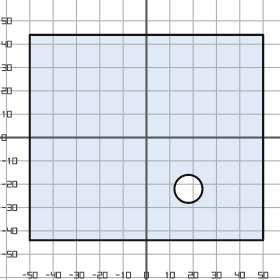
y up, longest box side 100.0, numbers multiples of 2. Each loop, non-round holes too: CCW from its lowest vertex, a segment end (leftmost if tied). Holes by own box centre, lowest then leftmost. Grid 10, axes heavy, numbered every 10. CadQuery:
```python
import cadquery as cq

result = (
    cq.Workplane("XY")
    .moveTo(-50.0, -44.0)
    .lineTo(50.0, -44.0)
    .lineTo(50.0, 44.0)
    .lineTo(-50.0, 44.0)
    .close()
    .moveTo(18.0, -22.0)
    .circle(6.0)
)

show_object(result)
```